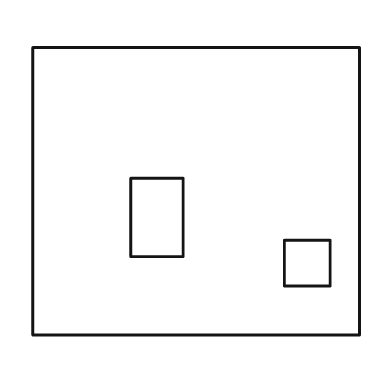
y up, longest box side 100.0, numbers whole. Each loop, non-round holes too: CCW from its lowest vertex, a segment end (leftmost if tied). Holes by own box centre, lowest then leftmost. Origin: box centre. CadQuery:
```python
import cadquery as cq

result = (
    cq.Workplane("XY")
    .moveTo(-50.0, -44.0)
    .lineTo(50.0, -44.0)
    .lineTo(50.0, 44.0)
    .lineTo(-50.0, 44.0)
    .close()
    .moveTo(27.0, -29.0)
    .lineTo(41.0, -29.0)
    .lineTo(41.0, -15.0)
    .lineTo(27.0, -15.0)
    .close()
    .moveTo(-20.0, -20.0)
    .lineTo(-4.0, -20.0)
    .lineTo(-4.0, 4.0)
    .lineTo(-20.0, 4.0)
    .close()
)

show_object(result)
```